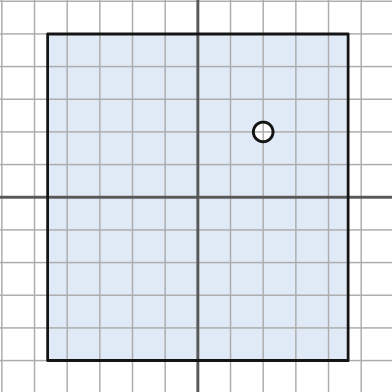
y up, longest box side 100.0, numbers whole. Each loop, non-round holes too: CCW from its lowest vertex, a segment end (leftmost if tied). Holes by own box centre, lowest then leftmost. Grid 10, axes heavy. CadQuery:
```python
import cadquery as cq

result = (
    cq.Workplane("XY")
    .moveTo(-46.0, -50.0)
    .lineTo(46.0, -50.0)
    .lineTo(46.0, 50.0)
    .lineTo(-46.0, 50.0)
    .close()
    .moveTo(20.0, 20.0)
    .circle(3.0)
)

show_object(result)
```